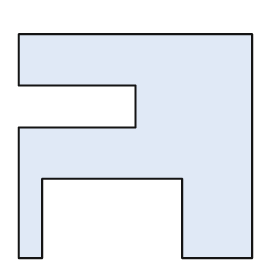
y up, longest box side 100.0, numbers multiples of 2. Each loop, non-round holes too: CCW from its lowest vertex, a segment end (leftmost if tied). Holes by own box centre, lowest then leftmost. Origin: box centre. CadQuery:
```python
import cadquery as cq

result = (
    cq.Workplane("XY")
    .moveTo(-50.0, -48.0)
    .lineTo(-40.0, -48.0)
    .lineTo(-40.0, -14.0)
    .lineTo(20.0, -14.0)
    .lineTo(20.0, -48.0)
    .lineTo(50.0, -48.0)
    .lineTo(50.0, 48.0)
    .lineTo(-50.0, 48.0)
    .lineTo(-50.0, 26.0)
    .lineTo(0.0, 26.0)
    .lineTo(0.0, 8.0)
    .lineTo(-50.0, 8.0)
    .close()
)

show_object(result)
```